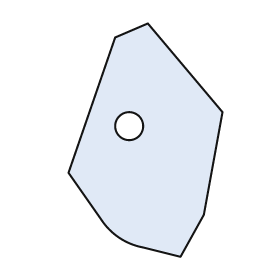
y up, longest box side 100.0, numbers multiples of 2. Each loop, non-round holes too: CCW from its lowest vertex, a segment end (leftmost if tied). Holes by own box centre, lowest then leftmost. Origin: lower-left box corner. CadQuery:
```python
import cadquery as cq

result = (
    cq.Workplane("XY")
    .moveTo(48.0, 0.0)
    .lineTo(58.0, 18.0)
    .lineTo(66.0, 62.0)
    .lineTo(34.0, 100.0)
    .lineTo(20.0, 94.0)
    .lineTo(0.0, 36.0)
    .lineTo(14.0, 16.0)
    .threePointArc((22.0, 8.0), (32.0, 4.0))
    .close()
    .moveTo(26.0, 56.0)
    .circle(6.0)
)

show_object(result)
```